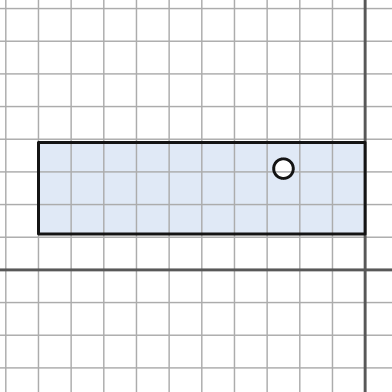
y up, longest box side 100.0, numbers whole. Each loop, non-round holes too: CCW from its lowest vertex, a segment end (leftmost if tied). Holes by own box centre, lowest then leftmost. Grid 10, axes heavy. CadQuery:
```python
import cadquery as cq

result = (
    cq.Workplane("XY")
    .moveTo(-100.0, 11.0)
    .lineTo(0.0, 11.0)
    .lineTo(0.0, 39.0)
    .lineTo(-100.0, 39.0)
    .close()
    .moveTo(-25.0, 31.0)
    .circle(3.0)
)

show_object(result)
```